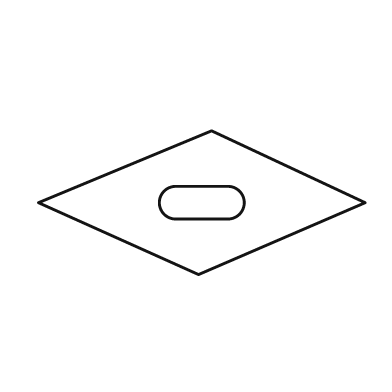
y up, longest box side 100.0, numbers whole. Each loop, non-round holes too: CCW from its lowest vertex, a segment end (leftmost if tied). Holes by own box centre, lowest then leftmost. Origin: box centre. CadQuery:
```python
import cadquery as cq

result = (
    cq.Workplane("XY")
    .moveTo(-1.0, -22.0)
    .lineTo(50.0, 0.0)
    .lineTo(3.0, 22.0)
    .lineTo(-50.0, 0.0)
    .close()
    .moveTo(-8.0, -5.0)
    .lineTo(8.0, -5.0)
    .threePointArc((13.0, 0.0), (8.0, 5.0))
    .lineTo(-8.0, 5.0)
    .threePointArc((-13.0, 0.0), (-8.0, -5.0))
    .close()
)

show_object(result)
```